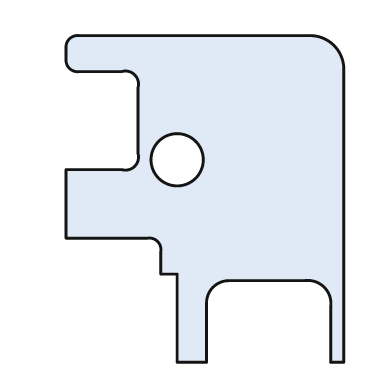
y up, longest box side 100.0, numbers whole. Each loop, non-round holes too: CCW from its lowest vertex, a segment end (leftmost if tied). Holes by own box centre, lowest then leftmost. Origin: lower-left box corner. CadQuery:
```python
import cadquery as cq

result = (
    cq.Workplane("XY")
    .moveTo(34.0, 0.0)
    .lineTo(43.0, 0.0)
    .lineTo(43.0, 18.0)
    .threePointArc((45.0, 23.0), (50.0, 25.0))
    .lineTo(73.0, 25.0)
    .threePointArc((79.0, 23.0), (81.0, 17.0))
    .lineTo(81.0, 0.0)
    .lineTo(85.0, 0.0)
    .lineTo(85.0, 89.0)
    .threePointArc((82.0, 97.0), (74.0, 100.0))
    .lineTo(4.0, 100.0)
    .threePointArc((1.0, 99.0), (0.0, 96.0))
    .lineTo(0.0, 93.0)
    .threePointArc((1.0, 90.0), (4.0, 89.0))
    .lineTo(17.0, 89.0)
    .threePointArc((21.0, 88.0), (22.0, 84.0))
    .lineTo(22.0, 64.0)
    .threePointArc((21.0, 60.0), (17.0, 59.0))
    .lineTo(0.0, 59.0)
    .lineTo(0.0, 38.0)
    .lineTo(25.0, 38.0)
    .threePointArc((28.0, 37.0), (29.0, 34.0))
    .lineTo(29.0, 27.0)
    .lineTo(34.0, 27.0)
    .close()
    .moveTo(34.0, 62.0)
    .circle(8.0)
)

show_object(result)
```